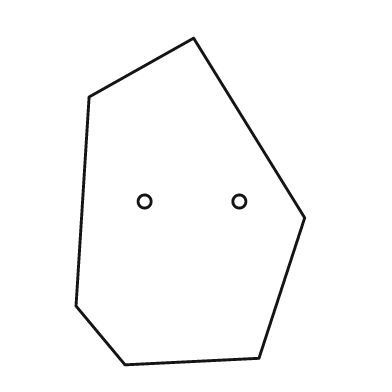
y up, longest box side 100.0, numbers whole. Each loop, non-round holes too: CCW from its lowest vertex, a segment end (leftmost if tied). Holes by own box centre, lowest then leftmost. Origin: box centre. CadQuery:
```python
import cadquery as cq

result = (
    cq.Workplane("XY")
    .moveTo(-20.0, -50.0)
    .lineTo(21.0, -48.0)
    .lineTo(35.0, -5.0)
    .lineTo(1.0, 50.0)
    .lineTo(-31.0, 32.0)
    .lineTo(-35.0, -32.0)
    .close()
    .moveTo(-14.0, 0.0)
    .circle(2.0)
    .moveTo(15.0, 0.0)
    .circle(2.0)
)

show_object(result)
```